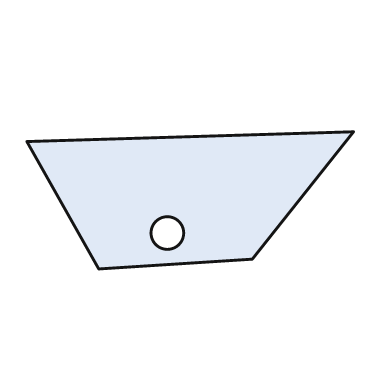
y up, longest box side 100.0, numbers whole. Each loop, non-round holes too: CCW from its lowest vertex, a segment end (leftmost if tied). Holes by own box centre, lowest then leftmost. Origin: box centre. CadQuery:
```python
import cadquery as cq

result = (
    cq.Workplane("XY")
    .moveTo(-28.0, -21.0)
    .lineTo(19.0, -18.0)
    .lineTo(50.0, 21.0)
    .lineTo(-50.0, 18.0)
    .close()
    .moveTo(-7.0, -10.0)
    .circle(5.0)
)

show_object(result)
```